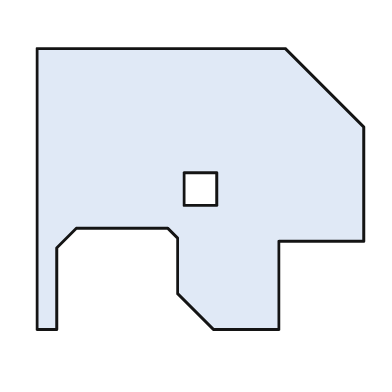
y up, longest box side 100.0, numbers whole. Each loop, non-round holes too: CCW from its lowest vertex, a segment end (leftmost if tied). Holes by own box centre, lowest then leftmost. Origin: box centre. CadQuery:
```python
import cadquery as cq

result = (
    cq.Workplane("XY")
    .moveTo(-50.0, -43.0)
    .lineTo(-44.0, -43.0)
    .lineTo(-44.0, -18.0)
    .lineTo(-38.0, -12.0)
    .lineTo(-10.0, -12.0)
    .lineTo(-7.0, -15.0)
    .lineTo(-7.0, -32.0)
    .lineTo(4.0, -43.0)
    .lineTo(24.0, -43.0)
    .lineTo(24.0, -16.0)
    .lineTo(50.0, -16.0)
    .lineTo(50.0, 19.0)
    .lineTo(26.0, 43.0)
    .lineTo(-50.0, 43.0)
    .close()
    .moveTo(-5.0, -5.0)
    .lineTo(5.0, -5.0)
    .lineTo(5.0, 5.0)
    .lineTo(-5.0, 5.0)
    .close()
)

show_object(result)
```